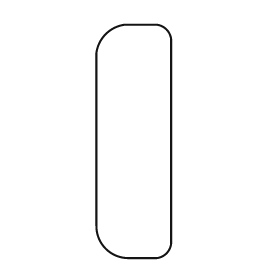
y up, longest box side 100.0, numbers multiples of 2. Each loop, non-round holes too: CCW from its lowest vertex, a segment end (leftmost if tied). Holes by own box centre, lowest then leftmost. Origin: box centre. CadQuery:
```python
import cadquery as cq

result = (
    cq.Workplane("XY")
    .moveTo(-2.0, -50.0)
    .lineTo(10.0, -50.0)
    .threePointArc((14.0, -48.0), (16.0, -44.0))
    .lineTo(16.0, 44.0)
    .threePointArc((14.0, 48.0), (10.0, 50.0))
    .lineTo(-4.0, 50.0)
    .threePointArc((-12.0, 46.0), (-16.0, 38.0))
    .lineTo(-16.0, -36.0)
    .threePointArc((-12.0, -46.0), (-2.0, -50.0))
    .close()
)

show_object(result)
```